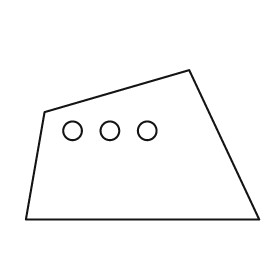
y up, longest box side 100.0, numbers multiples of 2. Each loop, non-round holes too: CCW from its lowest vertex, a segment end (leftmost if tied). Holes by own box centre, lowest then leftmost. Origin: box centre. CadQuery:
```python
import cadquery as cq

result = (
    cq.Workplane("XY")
    .moveTo(-50.0, -32.0)
    .lineTo(50.0, -32.0)
    .lineTo(20.0, 32.0)
    .lineTo(-42.0, 14.0)
    .close()
    .moveTo(-30.0, 6.0)
    .circle(4.0)
    .moveTo(-14.0, 6.0)
    .circle(4.0)
    .moveTo(2.0, 6.0)
    .circle(4.0)
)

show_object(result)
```